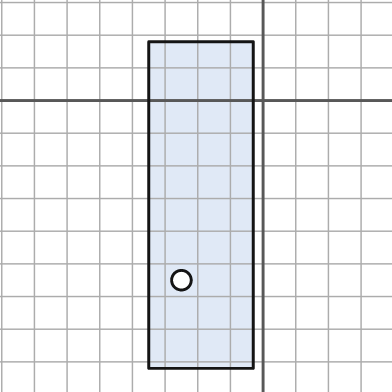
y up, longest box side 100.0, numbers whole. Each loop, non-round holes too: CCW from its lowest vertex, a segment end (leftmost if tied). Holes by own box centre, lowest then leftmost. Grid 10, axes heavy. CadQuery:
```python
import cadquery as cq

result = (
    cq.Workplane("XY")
    .moveTo(-35.0, -82.0)
    .lineTo(-3.0, -82.0)
    .lineTo(-3.0, 18.0)
    .lineTo(-35.0, 18.0)
    .close()
    .moveTo(-25.0, -55.0)
    .circle(3.0)
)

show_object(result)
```